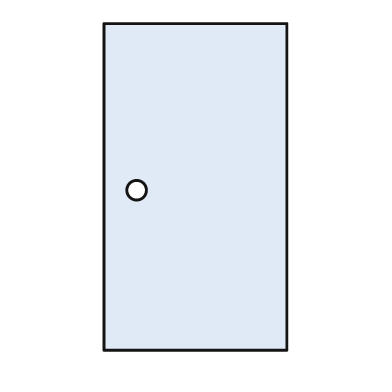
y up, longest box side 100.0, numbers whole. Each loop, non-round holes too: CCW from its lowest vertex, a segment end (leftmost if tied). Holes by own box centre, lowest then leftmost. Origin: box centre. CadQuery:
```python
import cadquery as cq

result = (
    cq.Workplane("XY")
    .moveTo(-28.0, -50.0)
    .lineTo(28.0, -50.0)
    .lineTo(28.0, 50.0)
    .lineTo(-28.0, 50.0)
    .close()
    .moveTo(-18.0, -1.0)
    .circle(3.0)
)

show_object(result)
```